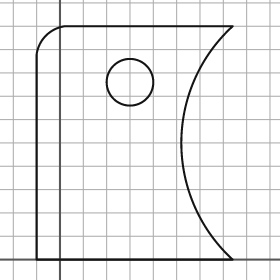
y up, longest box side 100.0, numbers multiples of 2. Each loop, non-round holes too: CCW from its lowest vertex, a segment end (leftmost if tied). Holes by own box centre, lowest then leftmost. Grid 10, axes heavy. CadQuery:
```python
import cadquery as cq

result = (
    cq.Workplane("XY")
    .moveTo(-10.0, 0.0)
    .lineTo(74.0, 0.0)
    .threePointArc((52.0, 50.0), (74.0, 100.0))
    .lineTo(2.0, 100.0)
    .threePointArc((-6.0, 96.0), (-10.0, 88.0))
    .close()
    .moveTo(30.0, 76.0)
    .circle(10.0)
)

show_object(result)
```